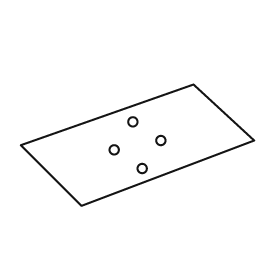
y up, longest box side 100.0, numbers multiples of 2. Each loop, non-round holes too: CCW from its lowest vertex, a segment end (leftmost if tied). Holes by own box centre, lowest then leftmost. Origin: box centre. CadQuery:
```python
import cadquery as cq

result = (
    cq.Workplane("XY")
    .moveTo(-24.0, -26.0)
    .lineTo(50.0, 2.0)
    .lineTo(24.0, 26.0)
    .lineTo(-50.0, 0.0)
    .close()
    .moveTo(2.0, -10.0)
    .circle(2.0)
    .moveTo(-10.0, -2.0)
    .circle(2.0)
    .moveTo(10.0, 2.0)
    .circle(2.0)
    .moveTo(-2.0, 10.0)
    .circle(2.0)
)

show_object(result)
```